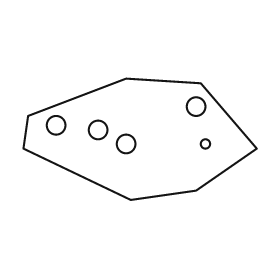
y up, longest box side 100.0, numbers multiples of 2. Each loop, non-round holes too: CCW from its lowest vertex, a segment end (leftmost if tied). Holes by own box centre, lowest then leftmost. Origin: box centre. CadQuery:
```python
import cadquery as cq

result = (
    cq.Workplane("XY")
    .moveTo(-4.0, -26.0)
    .lineTo(24.0, -22.0)
    .lineTo(50.0, -4.0)
    .lineTo(26.0, 24.0)
    .lineTo(-6.0, 26.0)
    .lineTo(-48.0, 10.0)
    .lineTo(-50.0, -4.0)
    .close()
    .moveTo(-6.0, -2.0)
    .circle(4.0)
    .moveTo(28.0, -2.0)
    .circle(2.0)
    .moveTo(-18.0, 4.0)
    .circle(4.0)
    .moveTo(-36.0, 6.0)
    .circle(4.0)
    .moveTo(24.0, 14.0)
    .circle(4.0)
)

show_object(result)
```